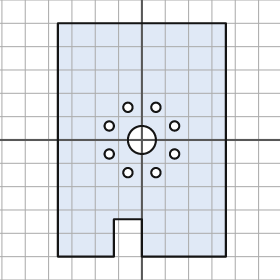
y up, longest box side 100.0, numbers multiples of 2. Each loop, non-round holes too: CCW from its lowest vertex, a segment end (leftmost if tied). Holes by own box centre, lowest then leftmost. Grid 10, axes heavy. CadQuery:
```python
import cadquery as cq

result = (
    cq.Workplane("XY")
    .moveTo(-36.0, -50.0)
    .lineTo(-12.0, -50.0)
    .lineTo(-12.0, -34.0)
    .lineTo(0.0, -34.0)
    .lineTo(0.0, -50.0)
    .lineTo(36.0, -50.0)
    .lineTo(36.0, 50.0)
    .lineTo(-36.0, 50.0)
    .close()
    .moveTo(-6.0, -14.0)
    .circle(2.0)
    .moveTo(6.0, -14.0)
    .circle(2.0)
    .moveTo(-14.0, -6.0)
    .circle(2.0)
    .moveTo(14.0, -6.0)
    .circle(2.0)
    .moveTo(0.0, 0.0)
    .circle(6.0)
    .moveTo(-14.0, 6.0)
    .circle(2.0)
    .moveTo(14.0, 6.0)
    .circle(2.0)
    .moveTo(-6.0, 14.0)
    .circle(2.0)
    .moveTo(6.0, 14.0)
    .circle(2.0)
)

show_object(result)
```